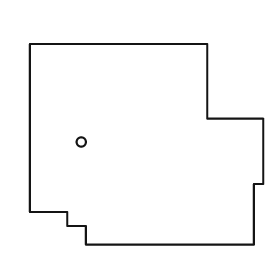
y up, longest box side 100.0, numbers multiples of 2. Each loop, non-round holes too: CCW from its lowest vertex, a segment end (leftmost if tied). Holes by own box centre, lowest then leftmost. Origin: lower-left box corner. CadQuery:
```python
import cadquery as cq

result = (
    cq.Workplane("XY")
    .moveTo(24.0, 0.0)
    .lineTo(96.0, 0.0)
    .lineTo(96.0, 26.0)
    .lineTo(100.0, 26.0)
    .lineTo(100.0, 54.0)
    .lineTo(76.0, 54.0)
    .lineTo(76.0, 86.0)
    .lineTo(0.0, 86.0)
    .lineTo(0.0, 14.0)
    .lineTo(16.0, 14.0)
    .lineTo(16.0, 8.0)
    .lineTo(24.0, 8.0)
    .close()
    .moveTo(22.0, 44.0)
    .circle(2.0)
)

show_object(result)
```